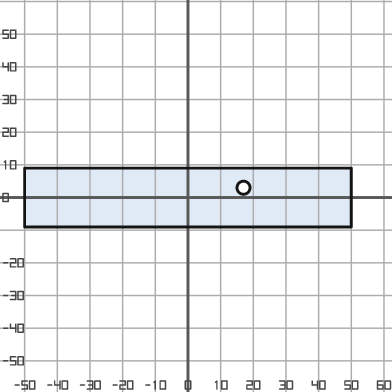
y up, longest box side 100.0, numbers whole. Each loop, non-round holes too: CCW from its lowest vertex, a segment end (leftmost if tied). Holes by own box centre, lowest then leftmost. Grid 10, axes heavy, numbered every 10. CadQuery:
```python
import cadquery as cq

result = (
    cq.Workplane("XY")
    .moveTo(-50.0, -9.0)
    .lineTo(50.0, -9.0)
    .lineTo(50.0, 9.0)
    .lineTo(-50.0, 9.0)
    .close()
    .moveTo(17.0, 3.0)
    .circle(2.0)
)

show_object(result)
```